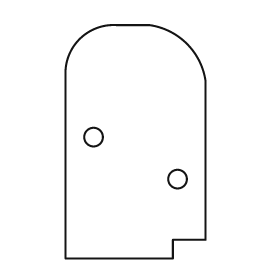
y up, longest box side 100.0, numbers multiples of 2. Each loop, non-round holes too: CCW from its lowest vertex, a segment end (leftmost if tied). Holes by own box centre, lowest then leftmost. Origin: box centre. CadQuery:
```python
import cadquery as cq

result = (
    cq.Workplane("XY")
    .moveTo(-30.0, -50.0)
    .lineTo(16.0, -50.0)
    .lineTo(16.0, -42.0)
    .lineTo(30.0, -42.0)
    .lineTo(30.0, 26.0)
    .threePointArc((22.0, 42.0), (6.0, 50.0))
    .lineTo(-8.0, 50.0)
    .threePointArc((-24.0, 44.0), (-30.0, 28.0))
    .close()
    .moveTo(18.0, -16.0)
    .circle(4.0)
    .moveTo(-18.0, 2.0)
    .circle(4.0)
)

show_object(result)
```